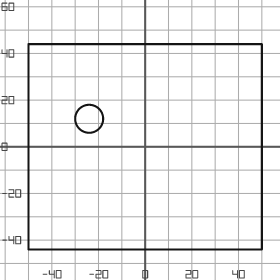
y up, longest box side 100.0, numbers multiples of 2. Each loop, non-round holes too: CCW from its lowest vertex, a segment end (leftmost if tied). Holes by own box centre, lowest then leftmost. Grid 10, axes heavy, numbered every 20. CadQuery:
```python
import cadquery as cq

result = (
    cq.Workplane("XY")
    .moveTo(-50.0, -44.0)
    .lineTo(50.0, -44.0)
    .lineTo(50.0, 44.0)
    .lineTo(-50.0, 44.0)
    .close()
    .moveTo(-24.0, 12.0)
    .circle(6.0)
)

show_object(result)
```